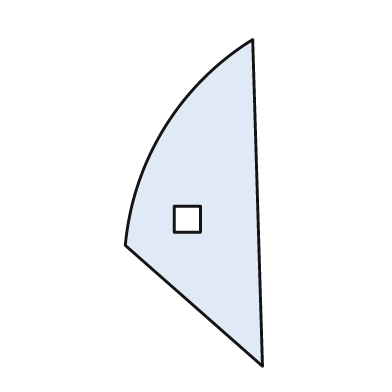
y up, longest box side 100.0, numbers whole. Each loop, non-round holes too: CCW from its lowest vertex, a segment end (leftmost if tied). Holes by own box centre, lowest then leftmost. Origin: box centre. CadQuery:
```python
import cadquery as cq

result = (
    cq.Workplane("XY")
    .moveTo(21.0, -50.0)
    .lineTo(18.0, 50.0)
    .threePointArc((-9.0, 23.0), (-21.0, -13.0))
    .close()
    .moveTo(-6.0, -9.0)
    .lineTo(2.0, -9.0)
    .lineTo(2.0, -1.0)
    .lineTo(-6.0, -1.0)
    .close()
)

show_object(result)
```